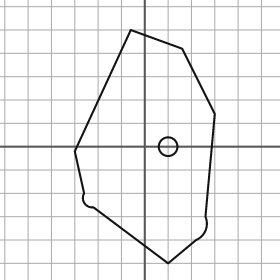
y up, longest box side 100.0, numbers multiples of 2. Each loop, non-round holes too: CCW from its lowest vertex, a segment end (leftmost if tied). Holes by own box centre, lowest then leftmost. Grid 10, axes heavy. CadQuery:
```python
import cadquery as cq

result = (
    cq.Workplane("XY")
    .moveTo(10.0, -50.0)
    .lineTo(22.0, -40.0)
    .threePointArc((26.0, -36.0), (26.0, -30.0))
    .lineTo(30.0, 14.0)
    .lineTo(16.0, 42.0)
    .lineTo(-6.0, 50.0)
    .lineTo(-30.0, -2.0)
    .lineTo(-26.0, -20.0)
    .threePointArc((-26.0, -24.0), (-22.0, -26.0))
    .close()
    .moveTo(10.0, 0.0)
    .circle(4.0)
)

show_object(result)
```